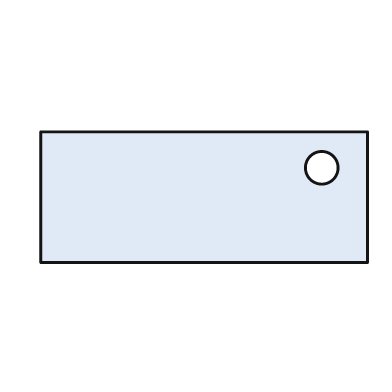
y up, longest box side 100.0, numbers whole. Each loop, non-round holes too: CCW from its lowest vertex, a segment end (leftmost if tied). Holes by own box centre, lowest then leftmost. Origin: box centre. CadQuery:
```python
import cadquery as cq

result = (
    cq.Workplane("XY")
    .moveTo(-50.0, -20.0)
    .lineTo(50.0, -20.0)
    .lineTo(50.0, 20.0)
    .lineTo(-50.0, 20.0)
    .close()
    .moveTo(36.0, 9.0)
    .circle(5.0)
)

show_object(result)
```